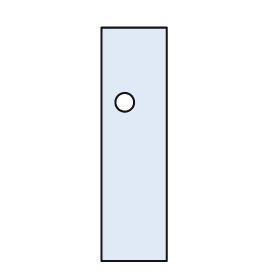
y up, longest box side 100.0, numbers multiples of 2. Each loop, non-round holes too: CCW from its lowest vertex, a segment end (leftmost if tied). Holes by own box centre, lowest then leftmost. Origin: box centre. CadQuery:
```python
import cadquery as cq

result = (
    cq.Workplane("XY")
    .moveTo(-14.0, -50.0)
    .lineTo(14.0, -50.0)
    .lineTo(14.0, 50.0)
    .lineTo(-14.0, 50.0)
    .close()
    .moveTo(-4.0, 18.0)
    .circle(4.0)
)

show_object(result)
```